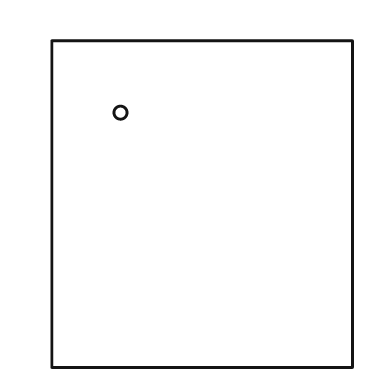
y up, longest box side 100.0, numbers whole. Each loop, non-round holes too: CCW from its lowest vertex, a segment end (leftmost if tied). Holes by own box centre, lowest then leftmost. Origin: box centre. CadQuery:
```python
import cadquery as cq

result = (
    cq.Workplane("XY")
    .moveTo(-46.0, -50.0)
    .lineTo(46.0, -50.0)
    .lineTo(46.0, 50.0)
    .lineTo(-46.0, 50.0)
    .close()
    .moveTo(-25.0, 28.0)
    .circle(2.0)
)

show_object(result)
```